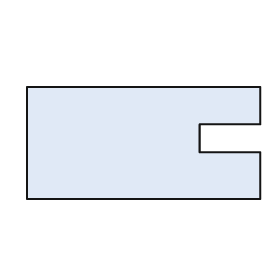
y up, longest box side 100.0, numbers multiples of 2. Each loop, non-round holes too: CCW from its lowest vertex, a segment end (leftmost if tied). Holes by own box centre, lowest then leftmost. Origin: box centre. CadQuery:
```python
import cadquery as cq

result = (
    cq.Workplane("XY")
    .moveTo(-50.0, -24.0)
    .lineTo(50.0, -24.0)
    .lineTo(50.0, -4.0)
    .lineTo(24.0, -4.0)
    .lineTo(24.0, 8.0)
    .lineTo(50.0, 8.0)
    .lineTo(50.0, 24.0)
    .lineTo(-50.0, 24.0)
    .close()
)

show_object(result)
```